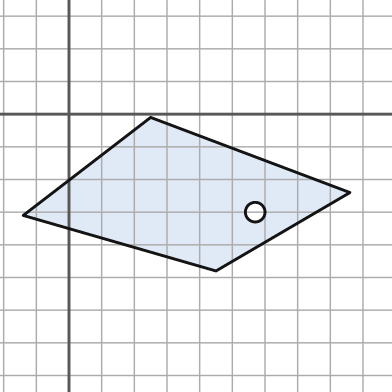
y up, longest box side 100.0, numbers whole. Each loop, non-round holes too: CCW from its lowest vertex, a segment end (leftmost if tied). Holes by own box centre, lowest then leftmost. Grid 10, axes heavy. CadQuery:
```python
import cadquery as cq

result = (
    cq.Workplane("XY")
    .moveTo(45.0, -48.0)
    .lineTo(86.0, -24.0)
    .lineTo(25.0, -1.0)
    .lineTo(-14.0, -31.0)
    .close()
    .moveTo(57.0, -30.0)
    .circle(3.0)
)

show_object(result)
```